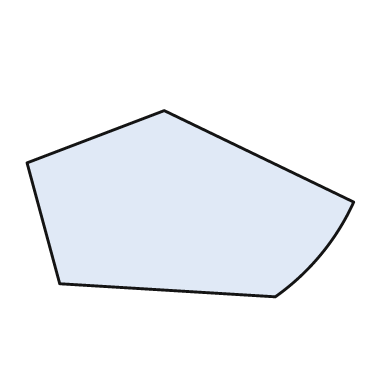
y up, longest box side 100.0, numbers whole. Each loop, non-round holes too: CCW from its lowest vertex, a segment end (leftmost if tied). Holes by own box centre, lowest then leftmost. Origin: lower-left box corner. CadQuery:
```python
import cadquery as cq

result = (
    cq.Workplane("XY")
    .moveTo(76.0, 0.0)
    .threePointArc((90.0, 13.0), (100.0, 29.0))
    .lineTo(42.0, 57.0)
    .lineTo(0.0, 41.0)
    .lineTo(10.0, 4.0)
    .close()
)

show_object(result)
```